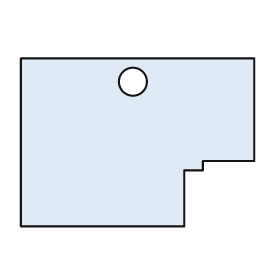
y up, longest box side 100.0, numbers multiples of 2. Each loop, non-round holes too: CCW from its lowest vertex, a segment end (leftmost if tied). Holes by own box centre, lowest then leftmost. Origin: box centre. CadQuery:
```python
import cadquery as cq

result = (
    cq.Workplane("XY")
    .moveTo(-50.0, -36.0)
    .lineTo(20.0, -36.0)
    .lineTo(20.0, -12.0)
    .lineTo(28.0, -12.0)
    .lineTo(28.0, -8.0)
    .lineTo(50.0, -8.0)
    .lineTo(50.0, 36.0)
    .lineTo(-50.0, 36.0)
    .close()
    .moveTo(-2.0, 26.0)
    .circle(6.0)
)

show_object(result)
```